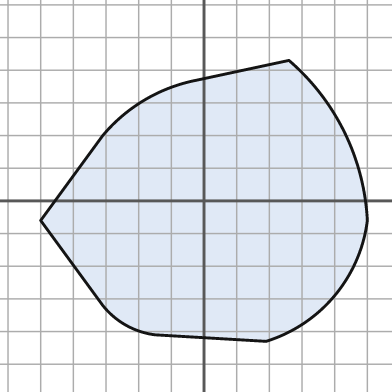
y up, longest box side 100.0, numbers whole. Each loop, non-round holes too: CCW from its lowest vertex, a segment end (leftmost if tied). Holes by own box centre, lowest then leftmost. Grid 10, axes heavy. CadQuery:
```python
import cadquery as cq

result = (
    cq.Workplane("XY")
    .moveTo(19.0, -43.0)
    .threePointArc((40.0, -29.0), (50.0, -6.0))
    .threePointArc((43.0, 21.0), (26.0, 43.0))
    .lineTo(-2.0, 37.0)
    .threePointArc((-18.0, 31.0), (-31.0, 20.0))
    .lineTo(-50.0, -6.0)
    .lineTo(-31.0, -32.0)
    .threePointArc((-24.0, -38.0), (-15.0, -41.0))
    .close()
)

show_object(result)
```